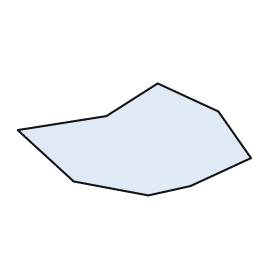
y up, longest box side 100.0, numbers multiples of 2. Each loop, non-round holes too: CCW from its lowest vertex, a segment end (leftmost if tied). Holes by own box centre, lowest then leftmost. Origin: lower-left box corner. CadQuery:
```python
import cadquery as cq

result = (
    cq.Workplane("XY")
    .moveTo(56.0, 0.0)
    .lineTo(74.0, 4.0)
    .lineTo(100.0, 16.0)
    .lineTo(86.0, 36.0)
    .lineTo(60.0, 48.0)
    .lineTo(38.0, 34.0)
    .lineTo(0.0, 28.0)
    .lineTo(24.0, 6.0)
    .close()
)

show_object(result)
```